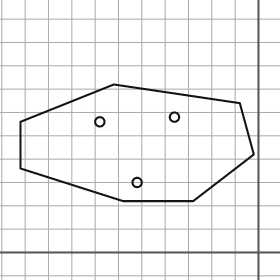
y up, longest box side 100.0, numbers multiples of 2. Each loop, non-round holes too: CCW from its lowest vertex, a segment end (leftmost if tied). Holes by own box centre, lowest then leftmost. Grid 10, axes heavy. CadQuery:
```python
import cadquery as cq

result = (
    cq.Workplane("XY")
    .moveTo(-58.0, 22.0)
    .lineTo(-28.0, 22.0)
    .lineTo(-2.0, 42.0)
    .lineTo(-8.0, 64.0)
    .lineTo(-62.0, 72.0)
    .lineTo(-102.0, 56.0)
    .lineTo(-102.0, 36.0)
    .close()
    .moveTo(-52.0, 30.0)
    .circle(2.0)
    .moveTo(-68.0, 56.0)
    .circle(2.0)
    .moveTo(-36.0, 58.0)
    .circle(2.0)
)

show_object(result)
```